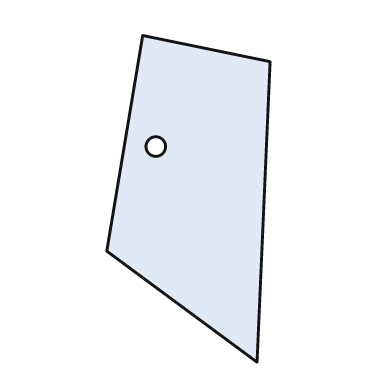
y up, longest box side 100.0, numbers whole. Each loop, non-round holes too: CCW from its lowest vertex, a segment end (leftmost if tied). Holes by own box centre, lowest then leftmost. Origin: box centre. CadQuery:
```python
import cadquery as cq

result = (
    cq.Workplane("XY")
    .moveTo(21.0, -50.0)
    .lineTo(25.0, 42.0)
    .lineTo(-14.0, 50.0)
    .lineTo(-25.0, -16.0)
    .close()
    .moveTo(-10.0, 16.0)
    .circle(3.0)
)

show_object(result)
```